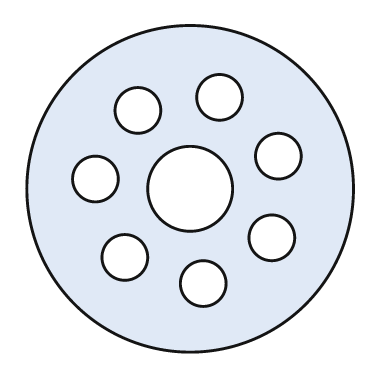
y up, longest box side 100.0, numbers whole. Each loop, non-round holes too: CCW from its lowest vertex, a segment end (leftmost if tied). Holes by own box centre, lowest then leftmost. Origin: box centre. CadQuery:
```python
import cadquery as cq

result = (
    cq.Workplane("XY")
    .moveTo(0.0, 0.0)
    .circle(50.0)
    .moveTo(4.0, -29.0)
    .circle(7.0)
    .moveTo(-20.0, -21.0)
    .circle(7.0)
    .moveTo(25.0, -15.0)
    .circle(7.0)
    .moveTo(0.0, 0.0)
    .circle(13.0)
    .moveTo(-29.0, 3.0)
    .circle(7.0)
    .moveTo(27.0, 10.0)
    .circle(7.0)
    .moveTo(-16.0, 24.0)
    .circle(7.0)
    .moveTo(9.0, 28.0)
    .circle(7.0)
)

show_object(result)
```